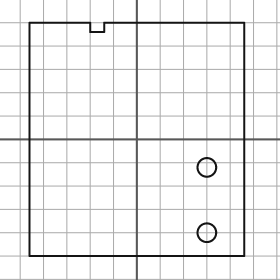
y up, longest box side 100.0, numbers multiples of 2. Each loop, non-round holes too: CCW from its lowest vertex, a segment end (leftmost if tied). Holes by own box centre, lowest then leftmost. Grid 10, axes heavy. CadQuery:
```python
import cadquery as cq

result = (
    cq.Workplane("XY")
    .moveTo(-46.0, -50.0)
    .lineTo(46.0, -50.0)
    .lineTo(46.0, 50.0)
    .lineTo(-14.0, 50.0)
    .lineTo(-14.0, 46.0)
    .lineTo(-20.0, 46.0)
    .lineTo(-20.0, 50.0)
    .lineTo(-46.0, 50.0)
    .close()
    .moveTo(30.0, -40.0)
    .circle(4.0)
    .moveTo(30.0, -12.0)
    .circle(4.0)
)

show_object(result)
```